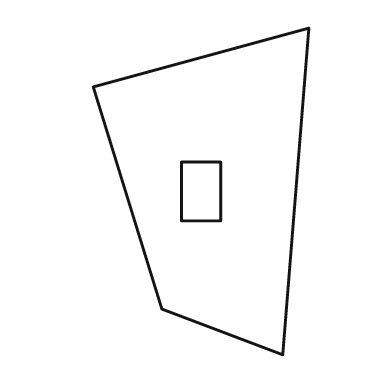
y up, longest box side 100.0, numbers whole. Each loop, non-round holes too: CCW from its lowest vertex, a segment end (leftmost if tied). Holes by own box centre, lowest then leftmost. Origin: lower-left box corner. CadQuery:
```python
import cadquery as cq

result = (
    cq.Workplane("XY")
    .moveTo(58.0, 0.0)
    .lineTo(66.0, 100.0)
    .lineTo(0.0, 82.0)
    .lineTo(21.0, 14.0)
    .close()
    .moveTo(27.0, 41.0)
    .lineTo(39.0, 41.0)
    .lineTo(39.0, 59.0)
    .lineTo(27.0, 59.0)
    .close()
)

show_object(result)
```